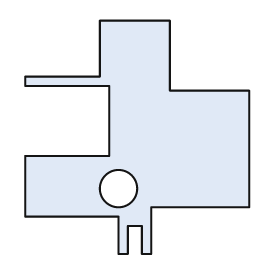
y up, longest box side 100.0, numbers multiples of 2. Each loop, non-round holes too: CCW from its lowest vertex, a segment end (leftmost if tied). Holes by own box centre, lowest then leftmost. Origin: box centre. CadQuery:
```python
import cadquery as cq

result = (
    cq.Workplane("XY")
    .moveTo(-8.0, -50.0)
    .lineTo(-4.0, -50.0)
    .lineTo(-4.0, -38.0)
    .lineTo(2.0, -38.0)
    .lineTo(2.0, -50.0)
    .lineTo(6.0, -50.0)
    .lineTo(6.0, -30.0)
    .lineTo(48.0, -30.0)
    .lineTo(48.0, 20.0)
    .lineTo(14.0, 20.0)
    .lineTo(14.0, 50.0)
    .lineTo(-16.0, 50.0)
    .lineTo(-16.0, 26.0)
    .lineTo(-48.0, 26.0)
    .lineTo(-48.0, 22.0)
    .lineTo(-12.0, 22.0)
    .lineTo(-12.0, -8.0)
    .lineTo(-48.0, -8.0)
    .lineTo(-48.0, -34.0)
    .lineTo(-8.0, -34.0)
    .close()
    .moveTo(-8.0, -22.0)
    .circle(8.0)
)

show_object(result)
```